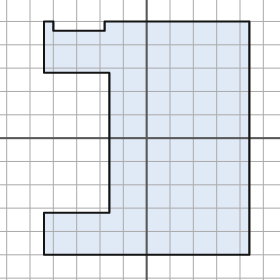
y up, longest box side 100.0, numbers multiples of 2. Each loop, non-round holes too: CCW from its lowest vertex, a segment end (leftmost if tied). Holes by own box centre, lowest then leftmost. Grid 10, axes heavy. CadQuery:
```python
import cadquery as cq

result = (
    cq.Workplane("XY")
    .moveTo(-44.0, -50.0)
    .lineTo(44.0, -50.0)
    .lineTo(44.0, 50.0)
    .lineTo(-18.0, 50.0)
    .lineTo(-18.0, 46.0)
    .lineTo(-40.0, 46.0)
    .lineTo(-40.0, 50.0)
    .lineTo(-44.0, 50.0)
    .lineTo(-44.0, 28.0)
    .lineTo(-16.0, 28.0)
    .lineTo(-16.0, -32.0)
    .lineTo(-44.0, -32.0)
    .close()
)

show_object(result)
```